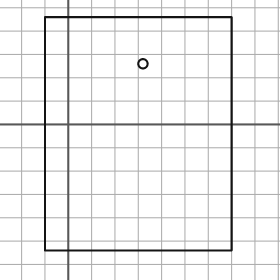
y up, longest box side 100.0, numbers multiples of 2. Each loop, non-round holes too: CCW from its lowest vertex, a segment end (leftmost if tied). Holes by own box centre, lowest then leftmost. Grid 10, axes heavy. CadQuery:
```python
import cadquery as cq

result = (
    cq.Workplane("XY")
    .moveTo(-10.0, -54.0)
    .lineTo(70.0, -54.0)
    .lineTo(70.0, 46.0)
    .lineTo(-10.0, 46.0)
    .close()
    .moveTo(32.0, 26.0)
    .circle(2.0)
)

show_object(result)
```